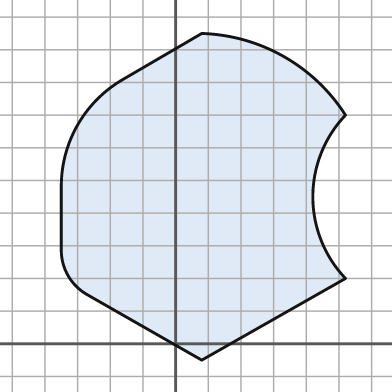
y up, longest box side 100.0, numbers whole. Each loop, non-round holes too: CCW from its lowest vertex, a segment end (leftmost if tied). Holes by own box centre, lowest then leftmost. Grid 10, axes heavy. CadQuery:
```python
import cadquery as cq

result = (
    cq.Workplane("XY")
    .moveTo(8.0, -5.0)
    .lineTo(52.0, 20.0)
    .threePointArc((42.0, 45.0), (52.0, 70.0))
    .threePointArc((33.0, 88.0), (8.0, 95.0))
    .lineTo(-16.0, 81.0)
    .threePointArc((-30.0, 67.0), (-35.0, 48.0))
    .lineTo(-35.0, 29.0)
    .threePointArc((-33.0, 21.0), (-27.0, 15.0))
    .close()
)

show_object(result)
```